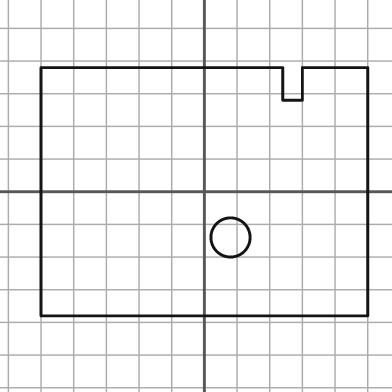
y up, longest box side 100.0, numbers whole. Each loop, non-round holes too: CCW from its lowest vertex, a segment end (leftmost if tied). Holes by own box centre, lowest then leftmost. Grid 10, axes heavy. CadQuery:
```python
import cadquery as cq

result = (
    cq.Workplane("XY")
    .moveTo(-50.0, -38.0)
    .lineTo(50.0, -38.0)
    .lineTo(50.0, 38.0)
    .lineTo(30.0, 38.0)
    .lineTo(30.0, 28.0)
    .lineTo(24.0, 28.0)
    .lineTo(24.0, 38.0)
    .lineTo(-50.0, 38.0)
    .close()
    .moveTo(8.0, -14.0)
    .circle(6.0)
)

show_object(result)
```